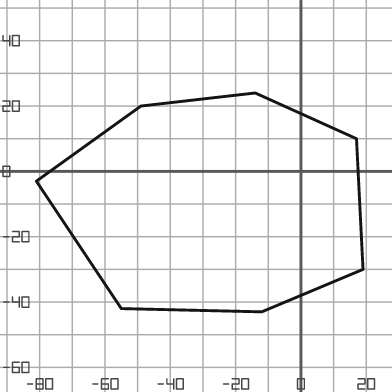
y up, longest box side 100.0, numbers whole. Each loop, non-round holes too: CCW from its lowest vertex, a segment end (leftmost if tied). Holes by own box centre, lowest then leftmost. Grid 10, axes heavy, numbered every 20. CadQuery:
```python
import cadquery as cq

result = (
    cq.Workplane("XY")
    .moveTo(-12.0, -43.0)
    .lineTo(19.0, -30.0)
    .lineTo(17.0, 10.0)
    .lineTo(-14.0, 24.0)
    .lineTo(-49.0, 20.0)
    .lineTo(-81.0, -3.0)
    .lineTo(-55.0, -42.0)
    .close()
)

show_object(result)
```